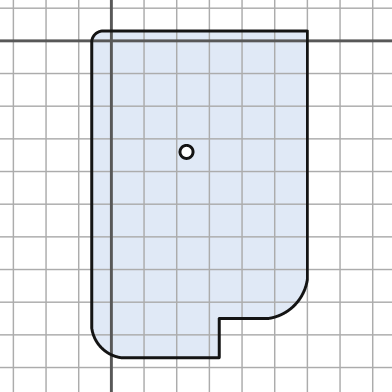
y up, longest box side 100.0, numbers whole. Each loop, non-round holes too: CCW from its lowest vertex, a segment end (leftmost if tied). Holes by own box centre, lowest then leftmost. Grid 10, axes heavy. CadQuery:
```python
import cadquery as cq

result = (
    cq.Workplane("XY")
    .moveTo(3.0, -97.0)
    .lineTo(33.0, -97.0)
    .lineTo(33.0, -85.0)
    .lineTo(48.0, -85.0)
    .threePointArc((56.0, -81.0), (60.0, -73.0))
    .lineTo(60.0, 3.0)
    .lineTo(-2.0, 3.0)
    .threePointArc((-5.0, 2.0), (-6.0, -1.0))
    .lineTo(-6.0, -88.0)
    .threePointArc((-3.0, -94.0), (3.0, -97.0))
    .close()
    .moveTo(23.0, -34.0)
    .circle(2.0)
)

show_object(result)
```